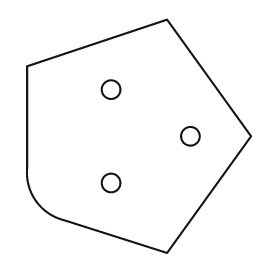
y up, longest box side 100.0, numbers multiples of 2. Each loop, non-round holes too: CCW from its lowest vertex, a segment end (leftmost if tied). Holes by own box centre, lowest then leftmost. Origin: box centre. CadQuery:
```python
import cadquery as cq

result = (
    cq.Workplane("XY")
    .moveTo(12.0, -50.0)
    .lineTo(48.0, 0.0)
    .lineTo(12.0, 50.0)
    .lineTo(-48.0, 30.0)
    .lineTo(-48.0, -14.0)
    .threePointArc((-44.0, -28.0), (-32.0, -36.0))
    .close()
    .moveTo(-12.0, -20.0)
    .circle(4.0)
    .moveTo(22.0, 0.0)
    .circle(4.0)
    .moveTo(-12.0, 20.0)
    .circle(4.0)
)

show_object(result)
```